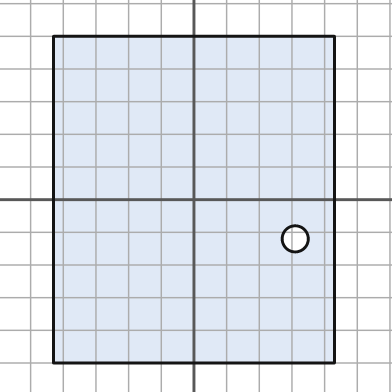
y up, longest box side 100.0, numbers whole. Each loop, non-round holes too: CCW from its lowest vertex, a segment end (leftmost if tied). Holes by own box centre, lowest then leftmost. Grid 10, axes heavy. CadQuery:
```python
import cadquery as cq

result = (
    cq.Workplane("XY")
    .moveTo(-43.0, -50.0)
    .lineTo(43.0, -50.0)
    .lineTo(43.0, 50.0)
    .lineTo(-43.0, 50.0)
    .close()
    .moveTo(31.0, -12.0)
    .circle(4.0)
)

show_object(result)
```